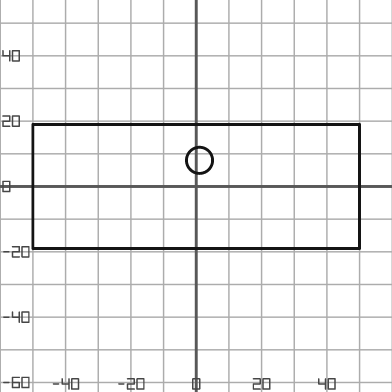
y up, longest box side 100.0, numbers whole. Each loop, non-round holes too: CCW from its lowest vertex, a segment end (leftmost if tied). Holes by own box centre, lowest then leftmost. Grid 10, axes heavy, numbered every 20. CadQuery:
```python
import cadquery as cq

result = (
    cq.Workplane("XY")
    .moveTo(-50.0, -19.0)
    .lineTo(50.0, -19.0)
    .lineTo(50.0, 19.0)
    .lineTo(-50.0, 19.0)
    .close()
    .moveTo(1.0, 8.0)
    .circle(4.0)
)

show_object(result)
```